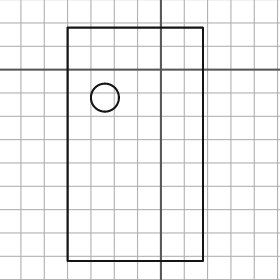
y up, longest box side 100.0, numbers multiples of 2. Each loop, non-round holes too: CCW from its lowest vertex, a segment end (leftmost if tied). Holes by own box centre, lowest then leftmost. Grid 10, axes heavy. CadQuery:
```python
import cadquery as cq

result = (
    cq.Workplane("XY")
    .moveTo(-40.0, -82.0)
    .lineTo(18.0, -82.0)
    .lineTo(18.0, 18.0)
    .lineTo(-40.0, 18.0)
    .close()
    .moveTo(-24.0, -12.0)
    .circle(6.0)
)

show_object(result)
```